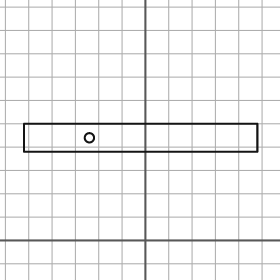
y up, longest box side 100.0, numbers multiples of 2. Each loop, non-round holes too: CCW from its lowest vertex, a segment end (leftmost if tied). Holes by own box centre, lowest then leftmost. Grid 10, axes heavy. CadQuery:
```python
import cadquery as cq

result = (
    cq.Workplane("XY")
    .moveTo(-52.0, 38.0)
    .lineTo(48.0, 38.0)
    .lineTo(48.0, 50.0)
    .lineTo(-52.0, 50.0)
    .close()
    .moveTo(-24.0, 44.0)
    .circle(2.0)
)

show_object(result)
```